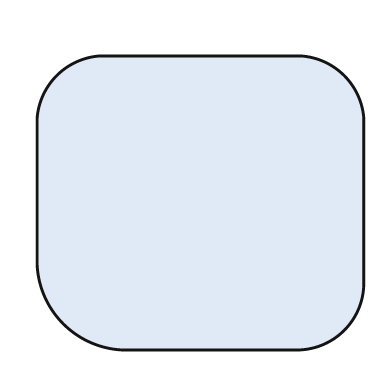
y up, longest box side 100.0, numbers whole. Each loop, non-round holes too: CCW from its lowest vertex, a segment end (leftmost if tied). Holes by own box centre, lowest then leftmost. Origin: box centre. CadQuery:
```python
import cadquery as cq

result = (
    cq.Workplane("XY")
    .moveTo(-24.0, -45.0)
    .lineTo(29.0, -45.0)
    .threePointArc((44.0, -39.0), (50.0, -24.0))
    .lineTo(50.0, 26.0)
    .threePointArc((44.0, 39.0), (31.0, 45.0))
    .lineTo(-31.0, 45.0)
    .threePointArc((-44.0, 39.0), (-50.0, 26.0))
    .lineTo(-50.0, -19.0)
    .threePointArc((-42.0, -37.0), (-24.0, -45.0))
    .close()
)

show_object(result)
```